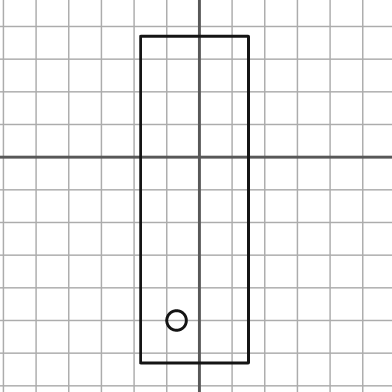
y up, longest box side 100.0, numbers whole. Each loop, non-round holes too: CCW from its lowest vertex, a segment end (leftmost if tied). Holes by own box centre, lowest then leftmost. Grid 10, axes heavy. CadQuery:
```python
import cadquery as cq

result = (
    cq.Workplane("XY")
    .moveTo(-18.0, -63.0)
    .lineTo(15.0, -63.0)
    .lineTo(15.0, 37.0)
    .lineTo(-18.0, 37.0)
    .close()
    .moveTo(-7.0, -50.0)
    .circle(3.0)
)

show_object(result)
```